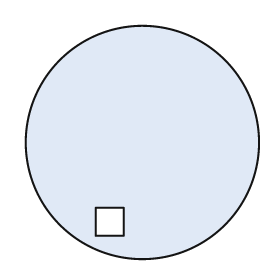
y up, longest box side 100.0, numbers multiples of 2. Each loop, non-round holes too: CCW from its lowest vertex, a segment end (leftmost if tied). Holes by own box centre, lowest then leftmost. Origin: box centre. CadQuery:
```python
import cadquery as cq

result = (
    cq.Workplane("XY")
    .moveTo(0.0, 0.0)
    .circle(50.0)
    .moveTo(-20.0, -40.0)
    .lineTo(-8.0, -40.0)
    .lineTo(-8.0, -28.0)
    .lineTo(-20.0, -28.0)
    .close()
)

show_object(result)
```